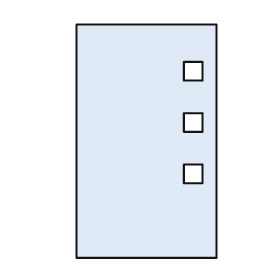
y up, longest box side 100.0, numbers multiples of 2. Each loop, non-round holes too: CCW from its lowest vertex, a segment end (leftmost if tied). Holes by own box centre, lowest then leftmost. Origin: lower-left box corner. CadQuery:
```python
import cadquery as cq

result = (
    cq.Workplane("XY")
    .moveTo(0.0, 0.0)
    .lineTo(60.0, 0.0)
    .lineTo(60.0, 100.0)
    .lineTo(0.0, 100.0)
    .close()
    .moveTo(46.0, 32.0)
    .lineTo(54.0, 32.0)
    .lineTo(54.0, 40.0)
    .lineTo(46.0, 40.0)
    .close()
    .moveTo(46.0, 54.0)
    .lineTo(54.0, 54.0)
    .lineTo(54.0, 62.0)
    .lineTo(46.0, 62.0)
    .close()
    .moveTo(46.0, 76.0)
    .lineTo(54.0, 76.0)
    .lineTo(54.0, 84.0)
    .lineTo(46.0, 84.0)
    .close()
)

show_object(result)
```